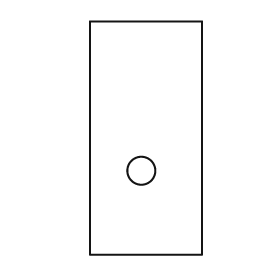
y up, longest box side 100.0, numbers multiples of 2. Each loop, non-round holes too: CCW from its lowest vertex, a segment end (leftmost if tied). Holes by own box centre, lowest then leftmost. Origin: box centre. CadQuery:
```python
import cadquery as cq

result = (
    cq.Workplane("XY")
    .moveTo(-24.0, -50.0)
    .lineTo(24.0, -50.0)
    .lineTo(24.0, 50.0)
    .lineTo(-24.0, 50.0)
    .close()
    .moveTo(-2.0, -14.0)
    .circle(6.0)
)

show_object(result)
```